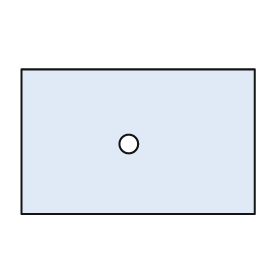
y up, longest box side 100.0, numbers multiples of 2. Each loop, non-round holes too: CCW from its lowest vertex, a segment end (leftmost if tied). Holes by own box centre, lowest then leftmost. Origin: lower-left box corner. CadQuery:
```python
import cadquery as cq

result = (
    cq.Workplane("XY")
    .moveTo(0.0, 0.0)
    .lineTo(100.0, 0.0)
    .lineTo(100.0, 62.0)
    .lineTo(0.0, 62.0)
    .close()
    .moveTo(46.0, 30.0)
    .circle(4.0)
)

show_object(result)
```